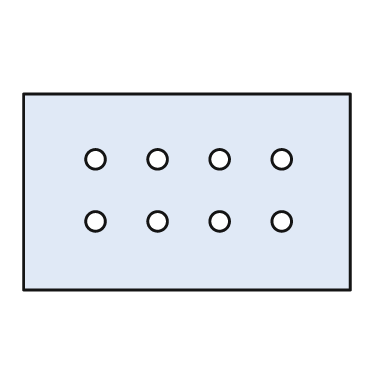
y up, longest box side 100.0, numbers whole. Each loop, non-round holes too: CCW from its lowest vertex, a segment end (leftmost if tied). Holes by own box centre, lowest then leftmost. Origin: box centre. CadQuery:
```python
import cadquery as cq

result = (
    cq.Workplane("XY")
    .moveTo(-50.0, -30.0)
    .lineTo(50.0, -30.0)
    .lineTo(50.0, 30.0)
    .lineTo(-50.0, 30.0)
    .close()
    .moveTo(-28.0, -9.0)
    .circle(3.0)
    .moveTo(-9.0, -9.0)
    .circle(3.0)
    .moveTo(10.0, -9.0)
    .circle(3.0)
    .moveTo(29.0, -9.0)
    .circle(3.0)
    .moveTo(-28.0, 10.0)
    .circle(3.0)
    .moveTo(-9.0, 10.0)
    .circle(3.0)
    .moveTo(10.0, 10.0)
    .circle(3.0)
    .moveTo(29.0, 10.0)
    .circle(3.0)
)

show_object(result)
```